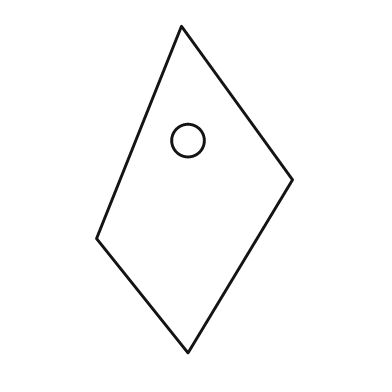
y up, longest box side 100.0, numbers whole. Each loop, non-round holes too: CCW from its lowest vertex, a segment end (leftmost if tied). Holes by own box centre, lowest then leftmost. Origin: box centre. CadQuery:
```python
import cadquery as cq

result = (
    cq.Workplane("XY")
    .moveTo(-2.0, -50.0)
    .lineTo(30.0, 3.0)
    .lineTo(-4.0, 50.0)
    .lineTo(-30.0, -15.0)
    .close()
    .moveTo(-2.0, 15.0)
    .circle(5.0)
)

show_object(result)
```